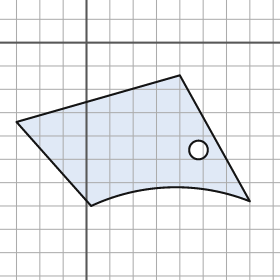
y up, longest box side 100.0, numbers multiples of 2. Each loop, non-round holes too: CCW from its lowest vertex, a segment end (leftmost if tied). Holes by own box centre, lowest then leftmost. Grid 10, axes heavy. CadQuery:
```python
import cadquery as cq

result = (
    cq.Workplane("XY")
    .moveTo(2.0, -70.0)
    .threePointArc((36.0, -62.0), (70.0, -68.0))
    .lineTo(40.0, -14.0)
    .lineTo(-30.0, -34.0)
    .close()
    .moveTo(48.0, -46.0)
    .circle(4.0)
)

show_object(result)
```